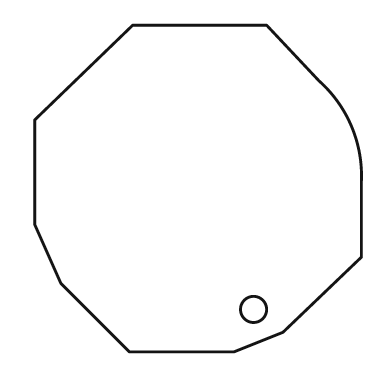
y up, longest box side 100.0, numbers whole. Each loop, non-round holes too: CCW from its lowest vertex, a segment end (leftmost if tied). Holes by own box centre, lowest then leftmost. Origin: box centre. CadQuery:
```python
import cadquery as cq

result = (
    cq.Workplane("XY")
    .moveTo(-21.0, -50.0)
    .lineTo(11.0, -50.0)
    .lineTo(26.0, -44.0)
    .lineTo(50.0, -21.0)
    .lineTo(50.0, 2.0)
    .threePointArc((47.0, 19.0), (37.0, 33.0))
    .lineTo(21.0, 50.0)
    .lineTo(-20.0, 50.0)
    .lineTo(-50.0, 21.0)
    .lineTo(-50.0, -11.0)
    .lineTo(-42.0, -29.0)
    .close()
    .moveTo(17.0, -37.0)
    .circle(4.0)
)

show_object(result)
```